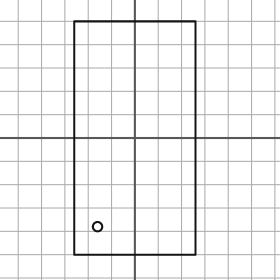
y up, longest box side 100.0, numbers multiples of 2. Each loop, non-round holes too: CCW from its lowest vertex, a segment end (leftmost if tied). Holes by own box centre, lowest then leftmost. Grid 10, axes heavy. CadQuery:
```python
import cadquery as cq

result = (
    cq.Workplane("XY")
    .moveTo(-26.0, -50.0)
    .lineTo(26.0, -50.0)
    .lineTo(26.0, 50.0)
    .lineTo(-26.0, 50.0)
    .close()
    .moveTo(-16.0, -38.0)
    .circle(2.0)
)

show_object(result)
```